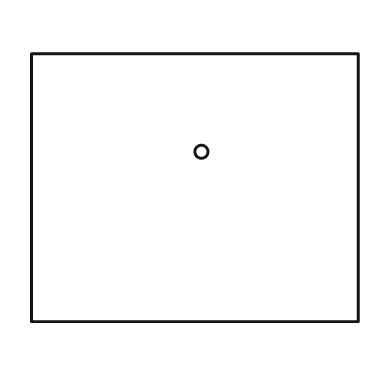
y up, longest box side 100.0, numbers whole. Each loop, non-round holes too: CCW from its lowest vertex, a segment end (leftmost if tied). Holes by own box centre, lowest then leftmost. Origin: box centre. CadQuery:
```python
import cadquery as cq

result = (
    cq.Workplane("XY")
    .moveTo(-50.0, -41.0)
    .lineTo(50.0, -41.0)
    .lineTo(50.0, 41.0)
    .lineTo(-50.0, 41.0)
    .close()
    .moveTo(2.0, 11.0)
    .circle(2.0)
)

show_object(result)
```